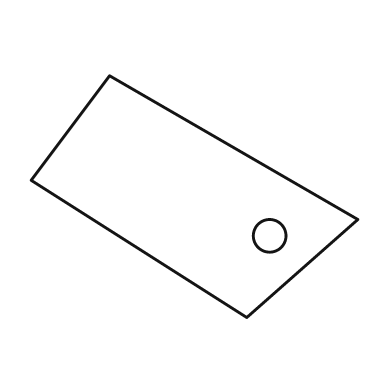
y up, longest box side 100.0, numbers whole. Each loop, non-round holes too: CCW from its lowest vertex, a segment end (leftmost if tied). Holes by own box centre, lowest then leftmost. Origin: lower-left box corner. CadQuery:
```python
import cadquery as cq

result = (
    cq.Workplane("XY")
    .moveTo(66.0, 0.0)
    .lineTo(100.0, 30.0)
    .lineTo(24.0, 74.0)
    .lineTo(0.0, 42.0)
    .close()
    .moveTo(73.0, 25.0)
    .circle(5.0)
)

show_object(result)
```